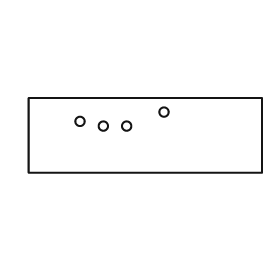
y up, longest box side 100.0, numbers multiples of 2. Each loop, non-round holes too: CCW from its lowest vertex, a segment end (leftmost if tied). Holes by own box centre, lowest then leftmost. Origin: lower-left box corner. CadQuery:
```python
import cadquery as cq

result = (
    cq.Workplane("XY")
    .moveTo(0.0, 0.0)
    .lineTo(100.0, 0.0)
    .lineTo(100.0, 32.0)
    .lineTo(0.0, 32.0)
    .close()
    .moveTo(32.0, 20.0)
    .circle(2.0)
    .moveTo(42.0, 20.0)
    .circle(2.0)
    .moveTo(22.0, 22.0)
    .circle(2.0)
    .moveTo(58.0, 26.0)
    .circle(2.0)
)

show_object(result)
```